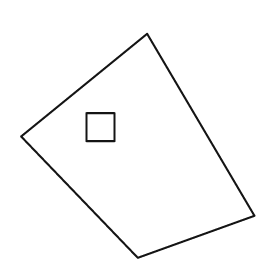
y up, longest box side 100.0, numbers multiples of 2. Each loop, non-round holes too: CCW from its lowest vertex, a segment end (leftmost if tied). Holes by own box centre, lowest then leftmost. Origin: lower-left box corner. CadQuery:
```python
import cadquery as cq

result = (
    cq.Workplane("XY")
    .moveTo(50.0, 0.0)
    .lineTo(100.0, 18.0)
    .lineTo(54.0, 96.0)
    .lineTo(0.0, 52.0)
    .close()
    .moveTo(28.0, 50.0)
    .lineTo(40.0, 50.0)
    .lineTo(40.0, 62.0)
    .lineTo(28.0, 62.0)
    .close()
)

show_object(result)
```